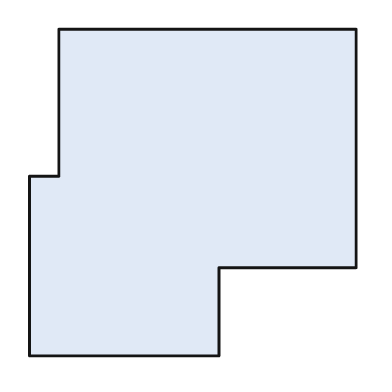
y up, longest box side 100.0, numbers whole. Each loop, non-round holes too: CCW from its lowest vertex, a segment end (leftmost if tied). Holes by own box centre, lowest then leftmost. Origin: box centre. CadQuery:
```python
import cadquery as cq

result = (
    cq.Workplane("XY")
    .moveTo(-50.0, -50.0)
    .lineTo(8.0, -50.0)
    .lineTo(8.0, -23.0)
    .lineTo(50.0, -23.0)
    .lineTo(50.0, 50.0)
    .lineTo(-41.0, 50.0)
    .lineTo(-41.0, 5.0)
    .lineTo(-50.0, 5.0)
    .close()
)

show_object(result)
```